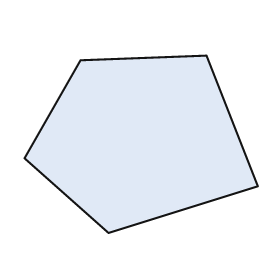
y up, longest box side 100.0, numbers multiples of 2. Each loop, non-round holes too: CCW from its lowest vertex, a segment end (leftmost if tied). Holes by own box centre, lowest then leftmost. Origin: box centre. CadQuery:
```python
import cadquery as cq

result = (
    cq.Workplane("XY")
    .moveTo(-14.0, -38.0)
    .lineTo(50.0, -18.0)
    .lineTo(28.0, 38.0)
    .lineTo(-26.0, 36.0)
    .lineTo(-50.0, -6.0)
    .close()
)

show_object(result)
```